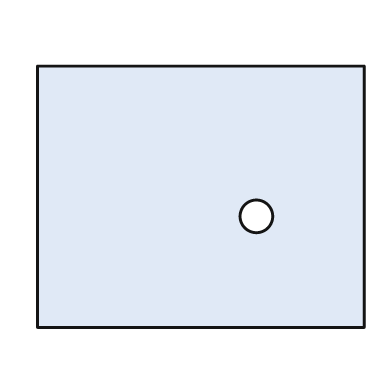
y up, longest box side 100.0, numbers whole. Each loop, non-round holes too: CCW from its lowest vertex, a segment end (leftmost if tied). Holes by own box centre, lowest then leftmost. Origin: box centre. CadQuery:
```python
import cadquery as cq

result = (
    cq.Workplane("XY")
    .moveTo(-50.0, -40.0)
    .lineTo(50.0, -40.0)
    .lineTo(50.0, 40.0)
    .lineTo(-50.0, 40.0)
    .close()
    .moveTo(17.0, -6.0)
    .circle(5.0)
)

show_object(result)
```